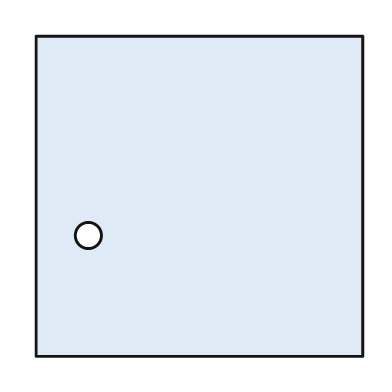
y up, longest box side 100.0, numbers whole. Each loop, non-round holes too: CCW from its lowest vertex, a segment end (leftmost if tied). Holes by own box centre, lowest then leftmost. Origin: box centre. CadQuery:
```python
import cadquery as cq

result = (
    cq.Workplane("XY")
    .moveTo(-50.0, -49.0)
    .lineTo(50.0, -49.0)
    .lineTo(50.0, 49.0)
    .lineTo(-50.0, 49.0)
    .close()
    .moveTo(-34.0, -12.0)
    .circle(4.0)
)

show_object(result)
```